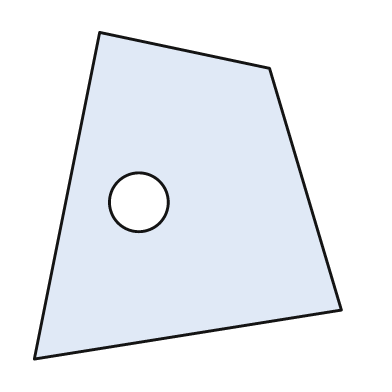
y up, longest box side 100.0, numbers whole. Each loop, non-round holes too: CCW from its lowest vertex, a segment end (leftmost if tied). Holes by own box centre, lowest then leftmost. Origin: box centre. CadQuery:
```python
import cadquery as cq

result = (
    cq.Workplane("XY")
    .moveTo(-47.0, -50.0)
    .lineTo(47.0, -35.0)
    .lineTo(25.0, 39.0)
    .lineTo(-27.0, 50.0)
    .close()
    .moveTo(-15.0, -2.0)
    .circle(9.0)
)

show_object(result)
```